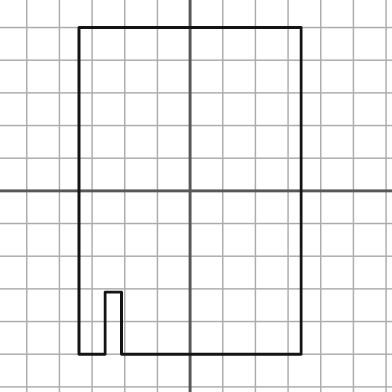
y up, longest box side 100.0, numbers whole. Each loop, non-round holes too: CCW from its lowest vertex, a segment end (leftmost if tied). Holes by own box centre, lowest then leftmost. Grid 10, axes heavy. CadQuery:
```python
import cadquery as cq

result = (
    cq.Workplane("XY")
    .moveTo(-34.0, -50.0)
    .lineTo(-26.0, -50.0)
    .lineTo(-26.0, -31.0)
    .lineTo(-21.0, -31.0)
    .lineTo(-21.0, -50.0)
    .lineTo(34.0, -50.0)
    .lineTo(34.0, 50.0)
    .lineTo(-34.0, 50.0)
    .close()
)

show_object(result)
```